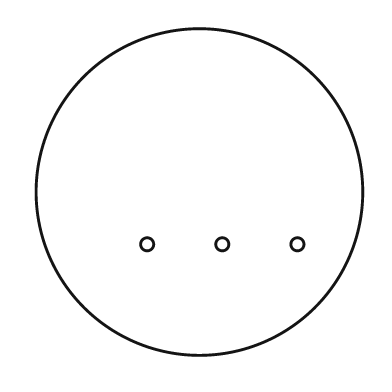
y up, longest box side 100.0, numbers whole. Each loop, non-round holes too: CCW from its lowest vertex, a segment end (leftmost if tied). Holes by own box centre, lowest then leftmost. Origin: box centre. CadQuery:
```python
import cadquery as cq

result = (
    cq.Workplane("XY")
    .moveTo(0.0, 0.0)
    .circle(50.0)
    .moveTo(-16.0, -16.0)
    .circle(2.0)
    .moveTo(7.0, -16.0)
    .circle(2.0)
    .moveTo(30.0, -16.0)
    .circle(2.0)
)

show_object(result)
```